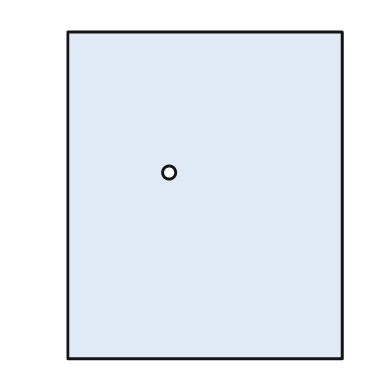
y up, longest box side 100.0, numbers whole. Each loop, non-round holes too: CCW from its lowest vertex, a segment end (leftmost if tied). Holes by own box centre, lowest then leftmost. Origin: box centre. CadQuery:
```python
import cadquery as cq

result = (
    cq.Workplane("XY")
    .moveTo(-42.0, -50.0)
    .lineTo(42.0, -50.0)
    .lineTo(42.0, 50.0)
    .lineTo(-42.0, 50.0)
    .close()
    .moveTo(-11.0, 7.0)
    .circle(2.0)
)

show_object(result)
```